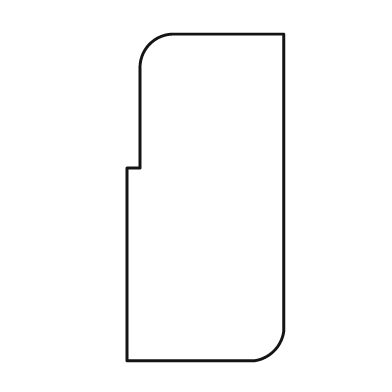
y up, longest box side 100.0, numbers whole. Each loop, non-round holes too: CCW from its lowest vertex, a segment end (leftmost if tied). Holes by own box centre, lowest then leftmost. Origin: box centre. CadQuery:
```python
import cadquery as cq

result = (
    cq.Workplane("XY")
    .moveTo(-24.0, -50.0)
    .lineTo(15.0, -50.0)
    .threePointArc((21.0, -47.0), (24.0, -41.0))
    .lineTo(24.0, 50.0)
    .lineTo(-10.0, 50.0)
    .threePointArc((-17.0, 47.0), (-20.0, 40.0))
    .lineTo(-20.0, 9.0)
    .lineTo(-24.0, 9.0)
    .close()
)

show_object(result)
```